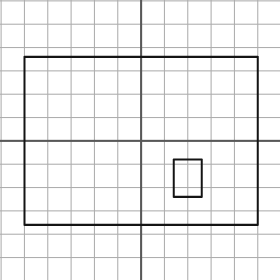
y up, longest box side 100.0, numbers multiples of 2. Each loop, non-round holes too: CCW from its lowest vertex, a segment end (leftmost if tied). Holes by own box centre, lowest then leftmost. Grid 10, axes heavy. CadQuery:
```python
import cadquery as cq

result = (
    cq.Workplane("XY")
    .moveTo(-50.0, -36.0)
    .lineTo(50.0, -36.0)
    .lineTo(50.0, 36.0)
    .lineTo(-50.0, 36.0)
    .close()
    .moveTo(14.0, -24.0)
    .lineTo(26.0, -24.0)
    .lineTo(26.0, -8.0)
    .lineTo(14.0, -8.0)
    .close()
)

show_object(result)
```